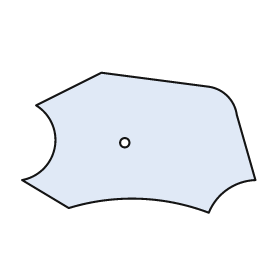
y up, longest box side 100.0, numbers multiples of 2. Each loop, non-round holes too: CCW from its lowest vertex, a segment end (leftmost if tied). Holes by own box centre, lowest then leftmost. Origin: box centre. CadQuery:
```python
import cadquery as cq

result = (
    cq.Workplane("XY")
    .moveTo(30.0, -30.0)
    .threePointArc((38.0, -20.0), (50.0, -16.0))
    .lineTo(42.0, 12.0)
    .threePointArc((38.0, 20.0), (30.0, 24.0))
    .lineTo(-16.0, 30.0)
    .lineTo(-44.0, 16.0)
    .threePointArc((-36.0, -2.0), (-50.0, -16.0))
    .lineTo(-30.0, -28.0)
    .threePointArc((0.0, -24.0), (30.0, -30.0))
    .close()
    .moveTo(-6.0, 0.0)
    .circle(2.0)
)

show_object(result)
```